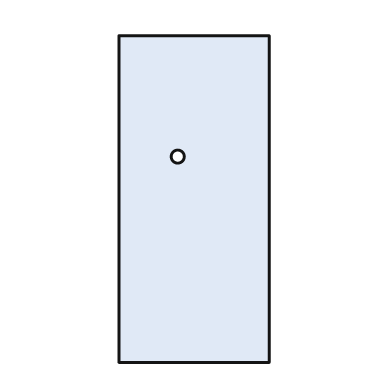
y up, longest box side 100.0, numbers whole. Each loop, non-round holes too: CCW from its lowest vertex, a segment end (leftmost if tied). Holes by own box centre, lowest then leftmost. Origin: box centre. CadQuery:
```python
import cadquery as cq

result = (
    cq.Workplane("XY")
    .moveTo(-23.0, -50.0)
    .lineTo(23.0, -50.0)
    .lineTo(23.0, 50.0)
    .lineTo(-23.0, 50.0)
    .close()
    .moveTo(-5.0, 13.0)
    .circle(2.0)
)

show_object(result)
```